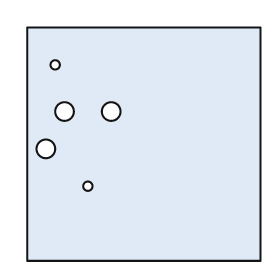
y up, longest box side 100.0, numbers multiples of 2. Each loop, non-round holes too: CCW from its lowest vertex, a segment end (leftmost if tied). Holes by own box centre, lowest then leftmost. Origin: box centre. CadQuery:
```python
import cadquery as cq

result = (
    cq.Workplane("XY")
    .moveTo(-50.0, -50.0)
    .lineTo(50.0, -50.0)
    .lineTo(50.0, 50.0)
    .lineTo(-50.0, 50.0)
    .close()
    .moveTo(-24.0, -18.0)
    .circle(2.0)
    .moveTo(-42.0, -2.0)
    .circle(4.0)
    .moveTo(-34.0, 14.0)
    .circle(4.0)
    .moveTo(-14.0, 14.0)
    .circle(4.0)
    .moveTo(-38.0, 34.0)
    .circle(2.0)
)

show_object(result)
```